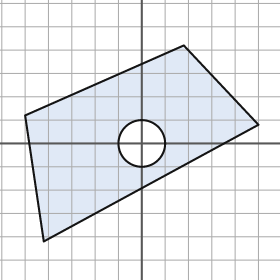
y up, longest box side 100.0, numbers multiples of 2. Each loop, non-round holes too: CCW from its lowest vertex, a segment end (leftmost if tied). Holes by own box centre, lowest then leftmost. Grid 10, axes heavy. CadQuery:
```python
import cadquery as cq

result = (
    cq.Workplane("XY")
    .moveTo(-42.0, -42.0)
    .lineTo(50.0, 8.0)
    .lineTo(18.0, 42.0)
    .lineTo(-50.0, 12.0)
    .close()
    .moveTo(0.0, 0.0)
    .circle(10.0)
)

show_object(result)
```